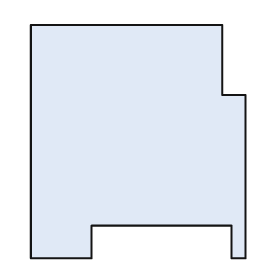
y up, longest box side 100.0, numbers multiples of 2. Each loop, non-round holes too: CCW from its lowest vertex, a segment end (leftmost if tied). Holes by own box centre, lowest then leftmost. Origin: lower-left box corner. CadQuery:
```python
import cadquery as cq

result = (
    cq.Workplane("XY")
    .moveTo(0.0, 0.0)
    .lineTo(26.0, 0.0)
    .lineTo(26.0, 14.0)
    .lineTo(86.0, 14.0)
    .lineTo(86.0, 0.0)
    .lineTo(92.0, 0.0)
    .lineTo(92.0, 70.0)
    .lineTo(82.0, 70.0)
    .lineTo(82.0, 100.0)
    .lineTo(0.0, 100.0)
    .close()
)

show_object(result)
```